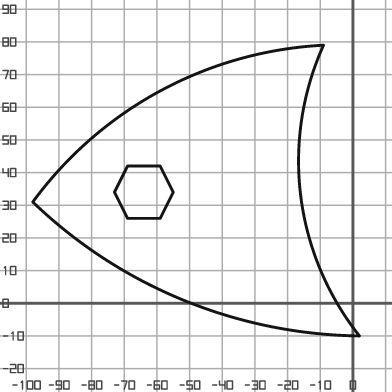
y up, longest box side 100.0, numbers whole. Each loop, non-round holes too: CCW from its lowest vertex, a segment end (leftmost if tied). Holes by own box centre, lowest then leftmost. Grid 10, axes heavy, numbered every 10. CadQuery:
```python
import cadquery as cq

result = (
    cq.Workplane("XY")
    .moveTo(2.0, -10.0)
    .threePointArc((-16.0, 33.0), (-9.0, 79.0))
    .threePointArc((-59.0, 65.0), (-98.0, 31.0))
    .threePointArc((-52.0, 1.0), (2.0, -10.0))
    .close()
    .moveTo(-69.0, 26.0)
    .lineTo(-59.0, 26.0)
    .lineTo(-55.0, 34.0)
    .lineTo(-59.0, 42.0)
    .lineTo(-69.0, 42.0)
    .lineTo(-73.0, 34.0)
    .close()
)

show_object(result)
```